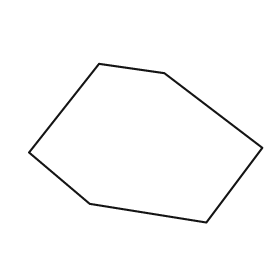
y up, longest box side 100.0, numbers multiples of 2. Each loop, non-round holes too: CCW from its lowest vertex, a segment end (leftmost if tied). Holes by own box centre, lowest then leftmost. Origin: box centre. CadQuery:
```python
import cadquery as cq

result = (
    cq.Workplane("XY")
    .moveTo(26.0, -34.0)
    .lineTo(50.0, -2.0)
    .lineTo(8.0, 30.0)
    .lineTo(-20.0, 34.0)
    .lineTo(-50.0, -4.0)
    .lineTo(-24.0, -26.0)
    .close()
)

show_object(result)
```